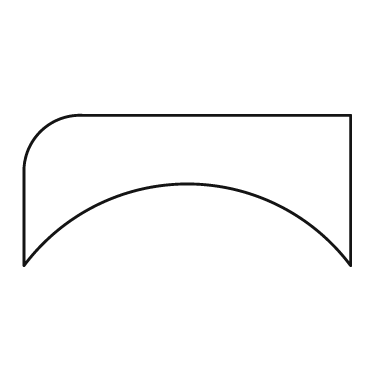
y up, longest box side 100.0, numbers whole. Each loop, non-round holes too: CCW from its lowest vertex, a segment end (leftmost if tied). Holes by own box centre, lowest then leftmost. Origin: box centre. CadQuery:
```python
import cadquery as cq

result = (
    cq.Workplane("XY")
    .moveTo(-50.0, -23.0)
    .threePointArc((0.0, 2.0), (50.0, -23.0))
    .lineTo(50.0, 23.0)
    .lineTo(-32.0, 23.0)
    .threePointArc((-45.0, 18.0), (-50.0, 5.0))
    .close()
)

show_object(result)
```